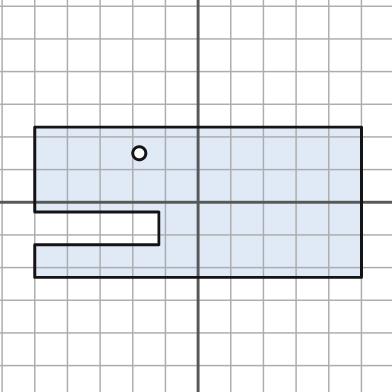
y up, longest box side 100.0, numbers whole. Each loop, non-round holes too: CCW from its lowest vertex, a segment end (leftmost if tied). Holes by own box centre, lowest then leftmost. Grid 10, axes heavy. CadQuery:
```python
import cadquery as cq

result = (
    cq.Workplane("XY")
    .moveTo(-50.0, -23.0)
    .lineTo(50.0, -23.0)
    .lineTo(50.0, 23.0)
    .lineTo(-50.0, 23.0)
    .lineTo(-50.0, -3.0)
    .lineTo(-12.0, -3.0)
    .lineTo(-12.0, -13.0)
    .lineTo(-50.0, -13.0)
    .close()
    .moveTo(-18.0, 15.0)
    .circle(2.0)
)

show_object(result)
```